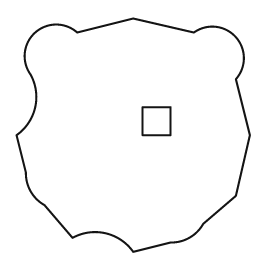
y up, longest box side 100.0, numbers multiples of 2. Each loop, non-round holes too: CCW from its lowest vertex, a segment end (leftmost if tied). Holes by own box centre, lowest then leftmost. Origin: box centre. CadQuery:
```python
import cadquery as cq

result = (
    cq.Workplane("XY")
    .moveTo(0.0, -50.0)
    .lineTo(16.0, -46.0)
    .threePointArc((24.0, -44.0), (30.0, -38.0))
    .lineTo(44.0, -26.0)
    .lineTo(50.0, 0.0)
    .lineTo(44.0, 24.0)
    .threePointArc((44.0, 42.0), (26.0, 44.0))
    .lineTo(0.0, 50.0)
    .lineTo(-24.0, 44.0)
    .threePointArc((-42.0, 44.0), (-44.0, 26.0))
    .threePointArc((-42.0, 12.0), (-50.0, 0.0))
    .lineTo(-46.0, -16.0)
    .threePointArc((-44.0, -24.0), (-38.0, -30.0))
    .lineTo(-26.0, -44.0)
    .threePointArc((-12.0, -42.0), (0.0, -50.0))
    .close()
    .moveTo(4.0, 0.0)
    .lineTo(16.0, 0.0)
    .lineTo(16.0, 12.0)
    .lineTo(4.0, 12.0)
    .close()
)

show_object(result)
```